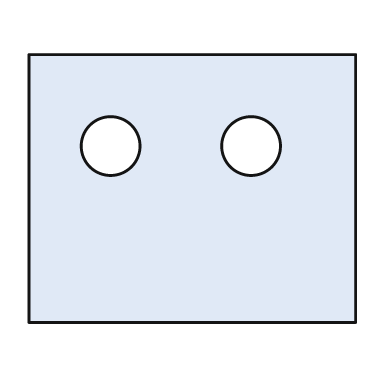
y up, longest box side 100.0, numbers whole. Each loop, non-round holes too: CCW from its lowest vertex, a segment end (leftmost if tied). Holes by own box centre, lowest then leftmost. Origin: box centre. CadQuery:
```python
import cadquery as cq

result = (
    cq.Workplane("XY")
    .moveTo(-50.0, -41.0)
    .lineTo(50.0, -41.0)
    .lineTo(50.0, 41.0)
    .lineTo(-50.0, 41.0)
    .close()
    .moveTo(-25.0, 13.0)
    .circle(9.0)
    .moveTo(18.0, 13.0)
    .circle(9.0)
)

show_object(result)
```